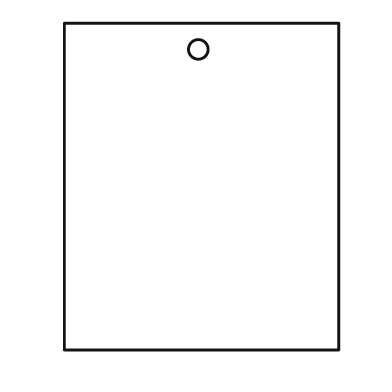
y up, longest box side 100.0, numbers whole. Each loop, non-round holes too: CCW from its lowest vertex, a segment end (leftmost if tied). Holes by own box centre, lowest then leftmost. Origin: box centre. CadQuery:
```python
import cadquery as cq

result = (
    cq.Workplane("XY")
    .moveTo(-42.0, -50.0)
    .lineTo(42.0, -50.0)
    .lineTo(42.0, 50.0)
    .lineTo(-42.0, 50.0)
    .close()
    .moveTo(-1.0, 42.0)
    .circle(3.0)
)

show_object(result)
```